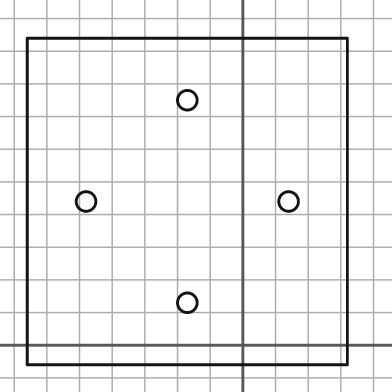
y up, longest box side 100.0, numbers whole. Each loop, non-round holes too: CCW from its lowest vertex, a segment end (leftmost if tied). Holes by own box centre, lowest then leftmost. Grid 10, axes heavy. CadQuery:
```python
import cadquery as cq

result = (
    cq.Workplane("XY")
    .moveTo(-66.0, -6.0)
    .lineTo(32.0, -6.0)
    .lineTo(32.0, 94.0)
    .lineTo(-66.0, 94.0)
    .close()
    .moveTo(-17.0, 13.0)
    .circle(3.0)
    .moveTo(-48.0, 44.0)
    .circle(3.0)
    .moveTo(14.0, 44.0)
    .circle(3.0)
    .moveTo(-17.0, 75.0)
    .circle(3.0)
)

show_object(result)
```